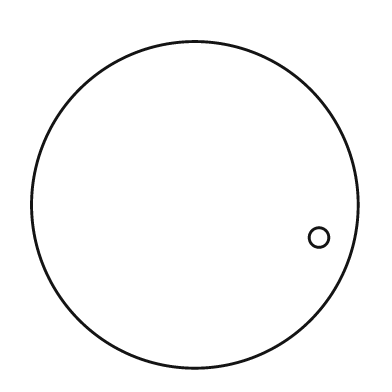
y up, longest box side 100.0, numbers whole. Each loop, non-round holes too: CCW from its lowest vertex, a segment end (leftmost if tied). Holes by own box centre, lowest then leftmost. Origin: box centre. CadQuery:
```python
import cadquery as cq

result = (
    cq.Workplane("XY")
    .moveTo(0.0, 0.0)
    .circle(50.0)
    .moveTo(38.0, -10.0)
    .circle(3.0)
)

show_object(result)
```